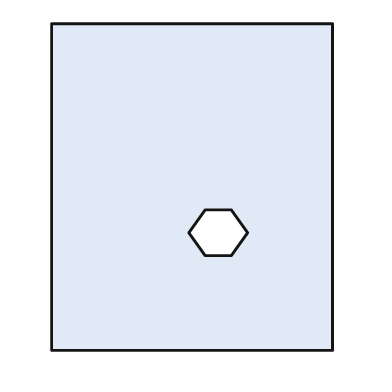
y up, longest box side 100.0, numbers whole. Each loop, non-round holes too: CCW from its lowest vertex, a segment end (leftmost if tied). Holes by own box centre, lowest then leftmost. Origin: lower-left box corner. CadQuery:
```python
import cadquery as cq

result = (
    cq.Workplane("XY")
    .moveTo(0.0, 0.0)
    .lineTo(86.0, 0.0)
    .lineTo(86.0, 100.0)
    .lineTo(0.0, 100.0)
    .close()
    .moveTo(47.0, 29.0)
    .lineTo(55.0, 29.0)
    .lineTo(60.0, 36.0)
    .lineTo(55.0, 43.0)
    .lineTo(47.0, 43.0)
    .lineTo(42.0, 36.0)
    .close()
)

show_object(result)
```